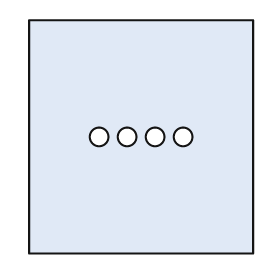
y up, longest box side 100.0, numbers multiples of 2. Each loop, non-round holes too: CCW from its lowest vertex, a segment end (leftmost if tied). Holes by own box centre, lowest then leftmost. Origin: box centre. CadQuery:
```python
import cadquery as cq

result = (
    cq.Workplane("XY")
    .moveTo(-48.0, -50.0)
    .lineTo(48.0, -50.0)
    .lineTo(48.0, 50.0)
    .lineTo(-48.0, 50.0)
    .close()
    .moveTo(-18.0, 0.0)
    .circle(4.0)
    .moveTo(-6.0, 0.0)
    .circle(4.0)
    .moveTo(6.0, 0.0)
    .circle(4.0)
    .moveTo(18.0, 0.0)
    .circle(4.0)
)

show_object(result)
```